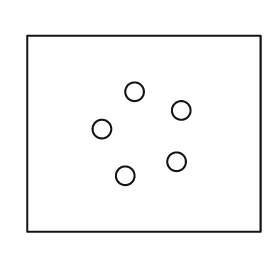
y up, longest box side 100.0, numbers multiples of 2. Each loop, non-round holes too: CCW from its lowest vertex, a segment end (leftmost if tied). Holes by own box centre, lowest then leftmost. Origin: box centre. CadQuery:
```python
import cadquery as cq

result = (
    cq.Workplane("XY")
    .moveTo(-50.0, -42.0)
    .lineTo(50.0, -42.0)
    .lineTo(50.0, 42.0)
    .lineTo(-50.0, 42.0)
    .close()
    .moveTo(-8.0, -18.0)
    .circle(4.0)
    .moveTo(14.0, -12.0)
    .circle(4.0)
    .moveTo(-18.0, 2.0)
    .circle(4.0)
    .moveTo(16.0, 10.0)
    .circle(4.0)
    .moveTo(-4.0, 18.0)
    .circle(4.0)
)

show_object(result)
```